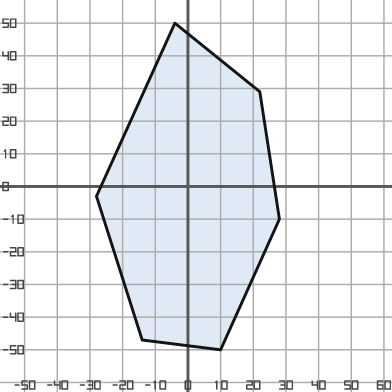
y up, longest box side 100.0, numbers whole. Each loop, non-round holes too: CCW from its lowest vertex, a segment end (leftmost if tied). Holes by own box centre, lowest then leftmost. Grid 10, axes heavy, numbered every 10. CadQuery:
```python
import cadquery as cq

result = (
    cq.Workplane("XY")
    .moveTo(10.0, -50.0)
    .lineTo(28.0, -10.0)
    .lineTo(22.0, 29.0)
    .lineTo(-4.0, 50.0)
    .lineTo(-28.0, -3.0)
    .lineTo(-14.0, -47.0)
    .close()
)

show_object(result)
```